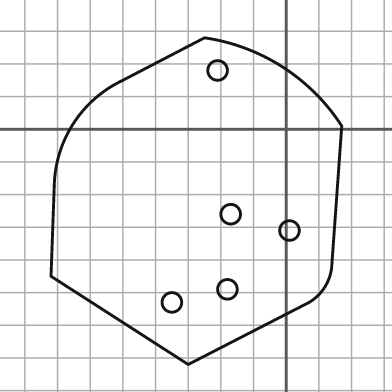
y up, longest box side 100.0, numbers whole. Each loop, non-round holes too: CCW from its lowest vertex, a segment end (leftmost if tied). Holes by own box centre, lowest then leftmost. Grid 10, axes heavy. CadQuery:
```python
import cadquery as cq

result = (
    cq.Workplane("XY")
    .moveTo(-30.0, -72.0)
    .lineTo(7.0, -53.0)
    .threePointArc((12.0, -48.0), (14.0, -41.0))
    .lineTo(17.0, 1.0)
    .threePointArc((-1.0, 19.0), (-25.0, 28.0))
    .lineTo(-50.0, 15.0)
    .threePointArc((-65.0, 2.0), (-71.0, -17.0))
    .lineTo(-72.0, -45.0)
    .close()
    .moveTo(-35.0, -53.0)
    .circle(3.0)
    .moveTo(-18.0, -49.0)
    .circle(3.0)
    .moveTo(1.0, -31.0)
    .circle(3.0)
    .moveTo(-17.0, -26.0)
    .circle(3.0)
    .moveTo(-21.0, 18.0)
    .circle(3.0)
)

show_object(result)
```